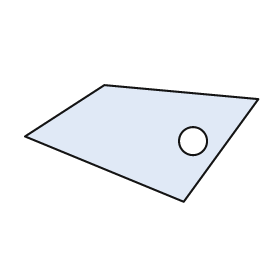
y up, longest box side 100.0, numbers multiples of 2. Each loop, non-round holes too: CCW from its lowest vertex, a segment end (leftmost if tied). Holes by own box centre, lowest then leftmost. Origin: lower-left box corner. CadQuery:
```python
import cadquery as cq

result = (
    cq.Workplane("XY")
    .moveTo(68.0, 0.0)
    .lineTo(100.0, 44.0)
    .lineTo(34.0, 50.0)
    .lineTo(0.0, 28.0)
    .close()
    .moveTo(72.0, 26.0)
    .circle(6.0)
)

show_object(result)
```